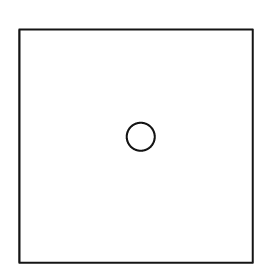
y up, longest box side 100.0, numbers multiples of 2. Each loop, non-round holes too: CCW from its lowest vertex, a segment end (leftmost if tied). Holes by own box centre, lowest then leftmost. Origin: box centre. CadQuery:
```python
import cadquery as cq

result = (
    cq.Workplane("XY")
    .moveTo(-50.0, -50.0)
    .lineTo(50.0, -50.0)
    .lineTo(50.0, 50.0)
    .lineTo(-50.0, 50.0)
    .close()
    .moveTo(2.0, 4.0)
    .circle(6.0)
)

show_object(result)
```